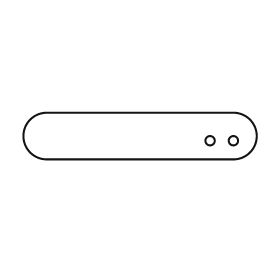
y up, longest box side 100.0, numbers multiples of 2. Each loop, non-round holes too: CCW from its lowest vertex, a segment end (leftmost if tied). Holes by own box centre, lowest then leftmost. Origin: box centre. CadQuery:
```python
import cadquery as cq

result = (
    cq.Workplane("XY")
    .moveTo(-40.0, -10.0)
    .lineTo(40.0, -10.0)
    .threePointArc((50.0, 0.0), (40.0, 10.0))
    .lineTo(-40.0, 10.0)
    .threePointArc((-50.0, 0.0), (-40.0, -10.0))
    .close()
    .moveTo(30.0, -2.0)
    .circle(2.0)
    .moveTo(40.0, -2.0)
    .circle(2.0)
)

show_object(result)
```